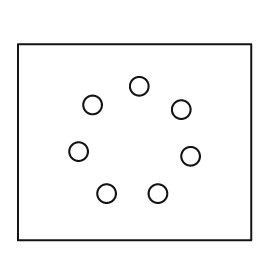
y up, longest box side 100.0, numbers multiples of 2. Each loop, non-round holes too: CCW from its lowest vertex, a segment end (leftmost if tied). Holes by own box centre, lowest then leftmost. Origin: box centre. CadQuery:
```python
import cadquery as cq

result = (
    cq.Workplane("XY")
    .moveTo(-50.0, -42.0)
    .lineTo(50.0, -42.0)
    .lineTo(50.0, 42.0)
    .lineTo(-50.0, 42.0)
    .close()
    .moveTo(-12.0, -22.0)
    .circle(4.0)
    .moveTo(10.0, -22.0)
    .circle(4.0)
    .moveTo(24.0, -6.0)
    .circle(4.0)
    .moveTo(-24.0, -4.0)
    .circle(4.0)
    .moveTo(20.0, 14.0)
    .circle(4.0)
    .moveTo(-18.0, 16.0)
    .circle(4.0)
    .moveTo(2.0, 24.0)
    .circle(4.0)
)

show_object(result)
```